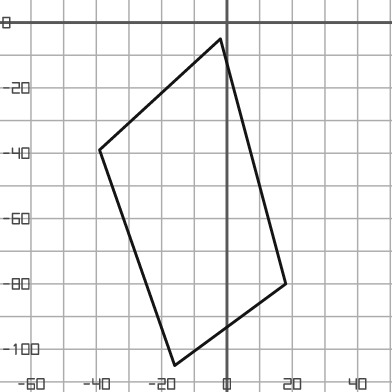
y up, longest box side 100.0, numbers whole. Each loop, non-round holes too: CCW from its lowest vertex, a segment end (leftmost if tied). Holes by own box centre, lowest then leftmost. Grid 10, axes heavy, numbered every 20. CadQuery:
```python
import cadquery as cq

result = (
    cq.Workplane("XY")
    .moveTo(-16.0, -105.0)
    .lineTo(18.0, -80.0)
    .lineTo(-2.0, -5.0)
    .lineTo(-39.0, -39.0)
    .close()
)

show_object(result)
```